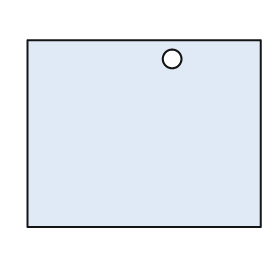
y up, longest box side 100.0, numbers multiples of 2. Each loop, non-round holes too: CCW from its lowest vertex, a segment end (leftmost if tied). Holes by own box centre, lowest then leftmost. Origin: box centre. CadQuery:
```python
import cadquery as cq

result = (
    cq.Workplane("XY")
    .moveTo(-50.0, -40.0)
    .lineTo(50.0, -40.0)
    .lineTo(50.0, 40.0)
    .lineTo(-50.0, 40.0)
    .close()
    .moveTo(12.0, 32.0)
    .circle(4.0)
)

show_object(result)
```